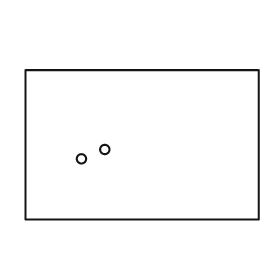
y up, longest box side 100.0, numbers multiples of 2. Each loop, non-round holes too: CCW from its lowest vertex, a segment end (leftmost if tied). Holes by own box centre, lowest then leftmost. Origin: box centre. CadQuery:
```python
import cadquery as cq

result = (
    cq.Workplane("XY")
    .moveTo(-50.0, -32.0)
    .lineTo(50.0, -32.0)
    .lineTo(50.0, 32.0)
    .lineTo(-50.0, 32.0)
    .close()
    .moveTo(-26.0, -6.0)
    .circle(2.0)
    .moveTo(-16.0, -2.0)
    .circle(2.0)
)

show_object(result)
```